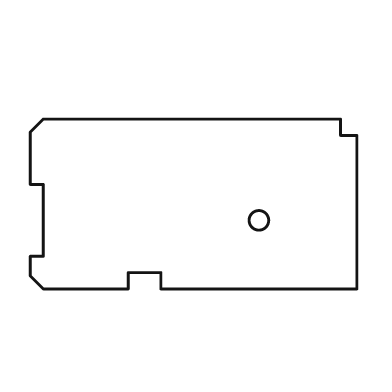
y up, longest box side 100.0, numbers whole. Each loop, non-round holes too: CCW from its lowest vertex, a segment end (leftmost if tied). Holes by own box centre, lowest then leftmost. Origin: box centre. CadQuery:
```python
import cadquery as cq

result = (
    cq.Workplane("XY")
    .moveTo(-46.0, -26.0)
    .lineTo(-20.0, -26.0)
    .lineTo(-20.0, -21.0)
    .lineTo(-10.0, -21.0)
    .lineTo(-10.0, -26.0)
    .lineTo(50.0, -26.0)
    .lineTo(50.0, 21.0)
    .lineTo(45.0, 21.0)
    .lineTo(45.0, 26.0)
    .lineTo(-46.0, 26.0)
    .lineTo(-50.0, 22.0)
    .lineTo(-50.0, 6.0)
    .lineTo(-46.0, 6.0)
    .lineTo(-46.0, -16.0)
    .lineTo(-50.0, -16.0)
    .lineTo(-50.0, -22.0)
    .close()
    .moveTo(20.0, -5.0)
    .circle(3.0)
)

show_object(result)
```